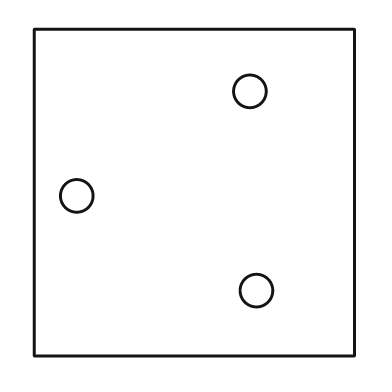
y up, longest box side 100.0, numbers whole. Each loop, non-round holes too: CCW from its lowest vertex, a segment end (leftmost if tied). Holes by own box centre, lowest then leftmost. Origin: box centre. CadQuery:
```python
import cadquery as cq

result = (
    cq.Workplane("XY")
    .moveTo(-49.0, -50.0)
    .lineTo(49.0, -50.0)
    .lineTo(49.0, 50.0)
    .lineTo(-49.0, 50.0)
    .close()
    .moveTo(19.0, -30.0)
    .circle(5.0)
    .moveTo(-36.0, -1.0)
    .circle(5.0)
    .moveTo(17.0, 31.0)
    .circle(5.0)
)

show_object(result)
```